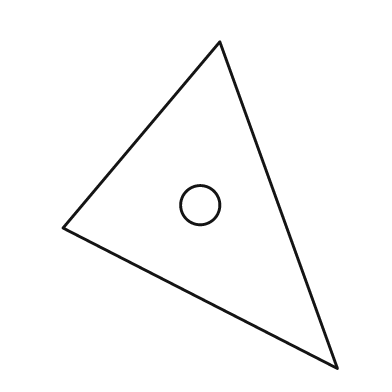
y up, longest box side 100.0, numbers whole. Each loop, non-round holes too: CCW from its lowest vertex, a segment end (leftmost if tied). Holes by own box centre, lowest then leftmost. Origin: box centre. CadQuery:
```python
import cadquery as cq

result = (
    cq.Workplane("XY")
    .moveTo(42.0, -50.0)
    .lineTo(6.0, 50.0)
    .lineTo(-42.0, -7.0)
    .close()
    .moveTo(0.0, 0.0)
    .circle(6.0)
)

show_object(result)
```